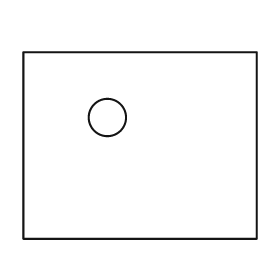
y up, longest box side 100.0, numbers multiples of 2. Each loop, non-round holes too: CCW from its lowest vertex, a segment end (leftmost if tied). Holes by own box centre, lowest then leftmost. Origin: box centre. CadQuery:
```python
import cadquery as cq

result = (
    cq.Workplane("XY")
    .moveTo(-50.0, -40.0)
    .lineTo(50.0, -40.0)
    .lineTo(50.0, 40.0)
    .lineTo(-50.0, 40.0)
    .close()
    .moveTo(-14.0, 12.0)
    .circle(8.0)
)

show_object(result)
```